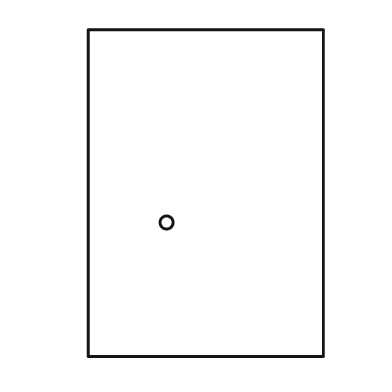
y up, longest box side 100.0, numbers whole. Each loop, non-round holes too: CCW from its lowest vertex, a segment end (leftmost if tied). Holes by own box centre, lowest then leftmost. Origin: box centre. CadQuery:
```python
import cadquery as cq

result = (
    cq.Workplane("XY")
    .moveTo(-36.0, -50.0)
    .lineTo(36.0, -50.0)
    .lineTo(36.0, 50.0)
    .lineTo(-36.0, 50.0)
    .close()
    .moveTo(-12.0, -9.0)
    .circle(2.0)
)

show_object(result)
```